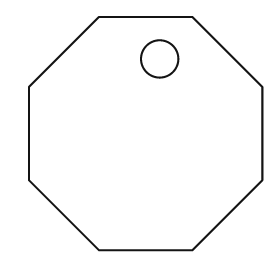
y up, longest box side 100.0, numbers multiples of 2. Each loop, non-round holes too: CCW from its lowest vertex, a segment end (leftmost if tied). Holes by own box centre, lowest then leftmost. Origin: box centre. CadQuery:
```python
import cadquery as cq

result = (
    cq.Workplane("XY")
    .moveTo(-20.0, -50.0)
    .lineTo(20.0, -50.0)
    .lineTo(50.0, -20.0)
    .lineTo(50.0, 20.0)
    .lineTo(20.0, 50.0)
    .lineTo(-20.0, 50.0)
    .lineTo(-50.0, 20.0)
    .lineTo(-50.0, -20.0)
    .close()
    .moveTo(6.0, 32.0)
    .circle(8.0)
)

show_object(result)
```